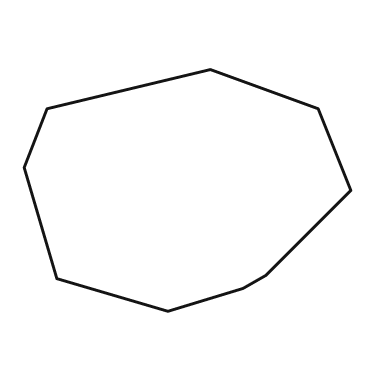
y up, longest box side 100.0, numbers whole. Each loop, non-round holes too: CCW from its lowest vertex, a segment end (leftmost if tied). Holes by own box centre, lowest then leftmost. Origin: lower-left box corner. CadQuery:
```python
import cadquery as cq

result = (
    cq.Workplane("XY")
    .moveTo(44.0, 0.0)
    .lineTo(67.0, 7.0)
    .lineTo(74.0, 11.0)
    .lineTo(100.0, 37.0)
    .lineTo(90.0, 62.0)
    .lineTo(57.0, 74.0)
    .lineTo(7.0, 62.0)
    .lineTo(0.0, 44.0)
    .lineTo(10.0, 10.0)
    .close()
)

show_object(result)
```